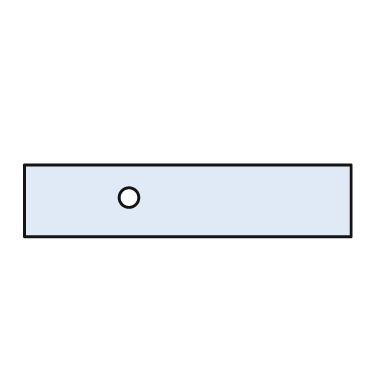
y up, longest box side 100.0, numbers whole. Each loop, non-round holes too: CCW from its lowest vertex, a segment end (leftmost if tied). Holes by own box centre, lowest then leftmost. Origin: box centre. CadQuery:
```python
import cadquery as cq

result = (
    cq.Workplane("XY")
    .moveTo(-50.0, -11.0)
    .lineTo(50.0, -11.0)
    .lineTo(50.0, 11.0)
    .lineTo(-50.0, 11.0)
    .close()
    .moveTo(-18.0, 1.0)
    .circle(3.0)
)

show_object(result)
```